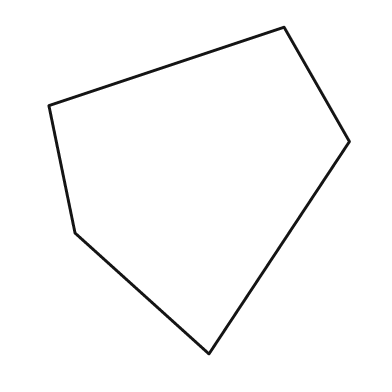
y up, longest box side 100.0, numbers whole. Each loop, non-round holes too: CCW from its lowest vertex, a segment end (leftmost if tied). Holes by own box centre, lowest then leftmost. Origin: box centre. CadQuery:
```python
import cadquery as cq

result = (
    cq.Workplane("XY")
    .moveTo(3.0, -50.0)
    .lineTo(46.0, 15.0)
    .lineTo(26.0, 50.0)
    .lineTo(-46.0, 26.0)
    .lineTo(-38.0, -13.0)
    .close()
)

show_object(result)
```